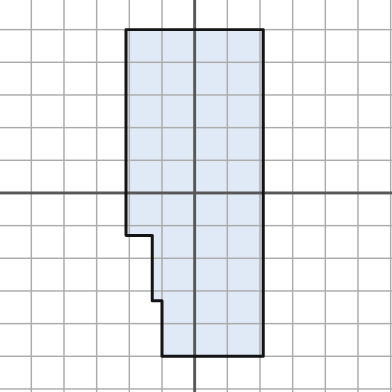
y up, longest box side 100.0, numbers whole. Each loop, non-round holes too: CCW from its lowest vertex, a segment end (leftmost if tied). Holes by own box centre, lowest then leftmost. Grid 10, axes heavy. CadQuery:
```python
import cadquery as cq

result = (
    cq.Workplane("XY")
    .moveTo(-10.0, -50.0)
    .lineTo(21.0, -50.0)
    .lineTo(21.0, 50.0)
    .lineTo(-21.0, 50.0)
    .lineTo(-21.0, -13.0)
    .lineTo(-13.0, -13.0)
    .lineTo(-13.0, -33.0)
    .lineTo(-10.0, -33.0)
    .close()
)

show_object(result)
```